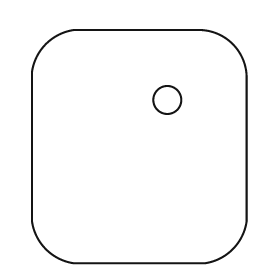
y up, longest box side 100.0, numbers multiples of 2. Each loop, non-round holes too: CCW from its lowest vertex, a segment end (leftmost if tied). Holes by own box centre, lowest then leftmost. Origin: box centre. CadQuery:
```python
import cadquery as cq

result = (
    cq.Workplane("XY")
    .moveTo(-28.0, -50.0)
    .lineTo(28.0, -50.0)
    .threePointArc((40.0, -44.0), (46.0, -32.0))
    .lineTo(46.0, 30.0)
    .threePointArc((40.0, 44.0), (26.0, 50.0))
    .lineTo(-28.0, 50.0)
    .threePointArc((-40.0, 44.0), (-46.0, 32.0))
    .lineTo(-46.0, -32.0)
    .threePointArc((-40.0, -44.0), (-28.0, -50.0))
    .close()
    .moveTo(12.0, 20.0)
    .circle(6.0)
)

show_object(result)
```